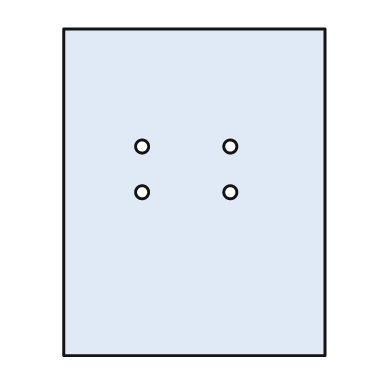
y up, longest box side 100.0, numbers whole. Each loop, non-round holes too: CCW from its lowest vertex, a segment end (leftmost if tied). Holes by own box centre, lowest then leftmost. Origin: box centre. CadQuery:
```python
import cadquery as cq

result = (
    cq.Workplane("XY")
    .moveTo(-40.0, -50.0)
    .lineTo(40.0, -50.0)
    .lineTo(40.0, 50.0)
    .lineTo(-40.0, 50.0)
    .close()
    .moveTo(-16.0, 0.0)
    .circle(2.0)
    .moveTo(11.0, 0.0)
    .circle(2.0)
    .moveTo(-16.0, 14.0)
    .circle(2.0)
    .moveTo(11.0, 14.0)
    .circle(2.0)
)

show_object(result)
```